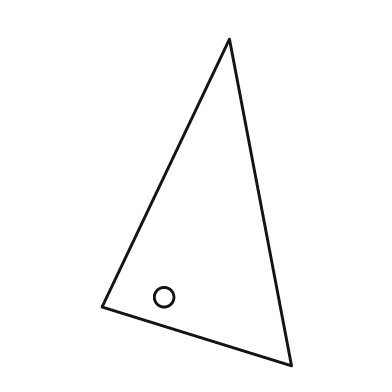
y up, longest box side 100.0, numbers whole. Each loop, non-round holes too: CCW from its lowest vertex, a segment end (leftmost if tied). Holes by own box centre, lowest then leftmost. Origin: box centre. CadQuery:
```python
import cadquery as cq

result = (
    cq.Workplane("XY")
    .moveTo(29.0, -50.0)
    .lineTo(10.0, 50.0)
    .lineTo(-29.0, -32.0)
    .close()
    .moveTo(-10.0, -29.0)
    .circle(3.0)
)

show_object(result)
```